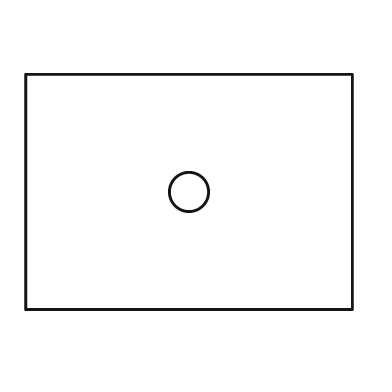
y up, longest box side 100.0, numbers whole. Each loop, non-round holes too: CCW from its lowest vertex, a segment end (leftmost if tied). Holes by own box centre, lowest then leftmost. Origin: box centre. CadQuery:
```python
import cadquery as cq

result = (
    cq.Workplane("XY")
    .moveTo(-50.0, -36.0)
    .lineTo(50.0, -36.0)
    .lineTo(50.0, 36.0)
    .lineTo(-50.0, 36.0)
    .close()
    .moveTo(0.0, 0.0)
    .circle(6.0)
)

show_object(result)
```